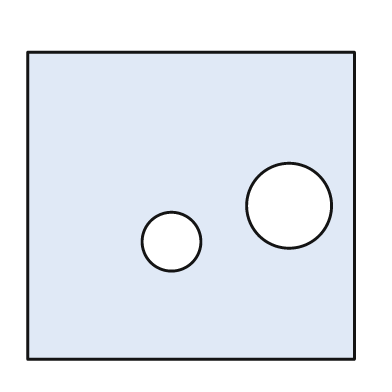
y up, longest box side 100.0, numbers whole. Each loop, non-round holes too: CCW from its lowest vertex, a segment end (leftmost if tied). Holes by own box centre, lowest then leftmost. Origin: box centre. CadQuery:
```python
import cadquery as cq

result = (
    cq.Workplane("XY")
    .moveTo(-50.0, -47.0)
    .lineTo(50.0, -47.0)
    .lineTo(50.0, 47.0)
    .lineTo(-50.0, 47.0)
    .close()
    .moveTo(-6.0, -11.0)
    .circle(9.0)
    .moveTo(30.0, 0.0)
    .circle(13.0)
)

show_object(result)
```